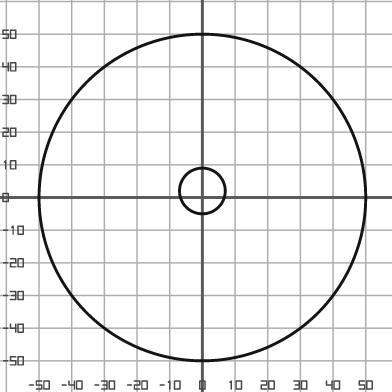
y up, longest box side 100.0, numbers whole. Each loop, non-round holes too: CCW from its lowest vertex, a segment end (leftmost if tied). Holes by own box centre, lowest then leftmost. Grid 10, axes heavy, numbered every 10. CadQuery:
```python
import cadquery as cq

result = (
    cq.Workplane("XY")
    .moveTo(0.0, 0.0)
    .circle(50.0)
    .moveTo(0.0, 2.0)
    .circle(7.0)
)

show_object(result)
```